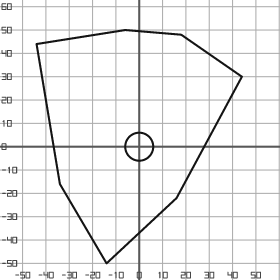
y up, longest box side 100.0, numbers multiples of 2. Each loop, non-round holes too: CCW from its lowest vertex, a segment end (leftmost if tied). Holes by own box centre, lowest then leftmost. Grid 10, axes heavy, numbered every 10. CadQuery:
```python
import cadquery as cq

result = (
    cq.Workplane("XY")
    .moveTo(-14.0, -50.0)
    .lineTo(16.0, -22.0)
    .lineTo(44.0, 30.0)
    .lineTo(18.0, 48.0)
    .lineTo(-6.0, 50.0)
    .lineTo(-44.0, 44.0)
    .lineTo(-34.0, -16.0)
    .close()
    .moveTo(0.0, 0.0)
    .circle(6.0)
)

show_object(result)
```